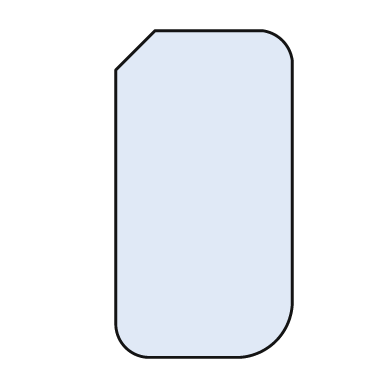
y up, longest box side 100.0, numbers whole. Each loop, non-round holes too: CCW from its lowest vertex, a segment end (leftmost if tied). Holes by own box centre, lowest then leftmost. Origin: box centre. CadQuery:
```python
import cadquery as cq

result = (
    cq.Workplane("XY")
    .moveTo(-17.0, -50.0)
    .lineTo(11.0, -50.0)
    .threePointArc((22.0, -45.0), (27.0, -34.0))
    .lineTo(27.0, 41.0)
    .threePointArc((24.0, 47.0), (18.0, 50.0))
    .lineTo(-15.0, 50.0)
    .lineTo(-27.0, 38.0)
    .lineTo(-27.0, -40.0)
    .threePointArc((-24.0, -47.0), (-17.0, -50.0))
    .close()
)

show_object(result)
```